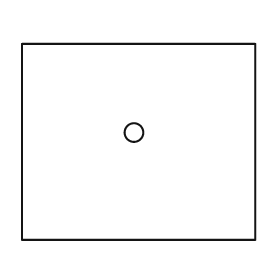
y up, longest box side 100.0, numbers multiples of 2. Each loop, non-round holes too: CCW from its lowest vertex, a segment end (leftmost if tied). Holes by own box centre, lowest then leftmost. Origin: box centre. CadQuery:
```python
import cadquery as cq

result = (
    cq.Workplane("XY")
    .moveTo(-50.0, -42.0)
    .lineTo(50.0, -42.0)
    .lineTo(50.0, 42.0)
    .lineTo(-50.0, 42.0)
    .close()
    .moveTo(-2.0, 4.0)
    .circle(4.0)
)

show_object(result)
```